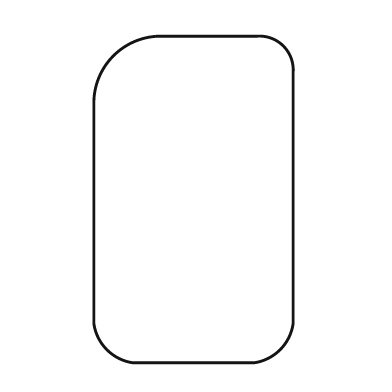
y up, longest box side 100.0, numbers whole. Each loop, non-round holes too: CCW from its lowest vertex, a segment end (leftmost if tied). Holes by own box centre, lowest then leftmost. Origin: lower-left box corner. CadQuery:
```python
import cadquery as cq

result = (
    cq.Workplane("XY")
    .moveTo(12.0, 0.0)
    .lineTo(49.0, 0.0)
    .threePointArc((57.0, 4.0), (61.0, 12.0))
    .lineTo(61.0, 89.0)
    .threePointArc((58.0, 97.0), (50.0, 100.0))
    .lineTo(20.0, 100.0)
    .threePointArc((6.0, 94.0), (0.0, 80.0))
    .lineTo(0.0, 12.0)
    .threePointArc((4.0, 4.0), (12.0, 0.0))
    .close()
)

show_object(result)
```